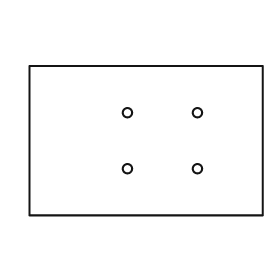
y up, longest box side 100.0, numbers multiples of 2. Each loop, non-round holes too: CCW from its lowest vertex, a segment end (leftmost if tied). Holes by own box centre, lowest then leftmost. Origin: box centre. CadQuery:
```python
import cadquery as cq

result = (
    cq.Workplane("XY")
    .moveTo(-50.0, -32.0)
    .lineTo(50.0, -32.0)
    .lineTo(50.0, 32.0)
    .lineTo(-50.0, 32.0)
    .close()
    .moveTo(-8.0, -12.0)
    .circle(2.0)
    .moveTo(22.0, -12.0)
    .circle(2.0)
    .moveTo(-8.0, 12.0)
    .circle(2.0)
    .moveTo(22.0, 12.0)
    .circle(2.0)
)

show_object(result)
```